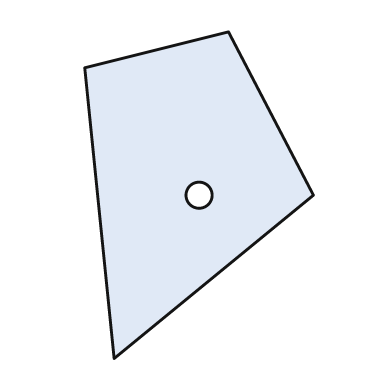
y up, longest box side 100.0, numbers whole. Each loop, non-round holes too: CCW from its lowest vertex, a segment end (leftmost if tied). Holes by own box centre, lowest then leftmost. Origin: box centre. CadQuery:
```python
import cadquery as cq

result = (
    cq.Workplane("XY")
    .moveTo(-26.0, -50.0)
    .lineTo(35.0, 0.0)
    .lineTo(9.0, 50.0)
    .lineTo(-35.0, 39.0)
    .close()
    .moveTo(0.0, 0.0)
    .circle(4.0)
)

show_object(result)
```